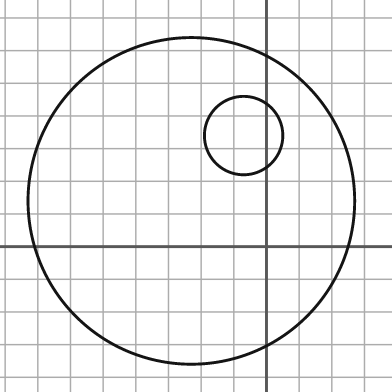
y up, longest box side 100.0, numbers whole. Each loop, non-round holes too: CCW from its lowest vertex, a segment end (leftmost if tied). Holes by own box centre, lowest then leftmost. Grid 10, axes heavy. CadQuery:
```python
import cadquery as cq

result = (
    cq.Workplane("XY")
    .moveTo(-23.0, 14.0)
    .circle(50.0)
    .moveTo(-7.0, 34.0)
    .circle(12.0)
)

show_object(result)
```